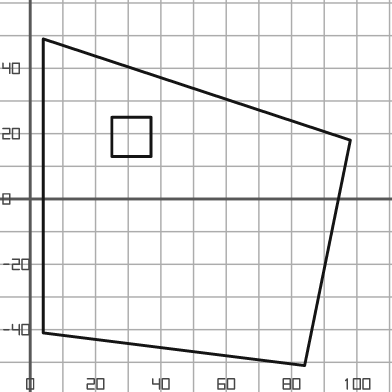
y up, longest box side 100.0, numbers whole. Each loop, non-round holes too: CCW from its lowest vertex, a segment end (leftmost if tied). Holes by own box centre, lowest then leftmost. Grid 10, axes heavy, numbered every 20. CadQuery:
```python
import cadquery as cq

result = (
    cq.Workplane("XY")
    .moveTo(84.0, -51.0)
    .lineTo(98.0, 18.0)
    .lineTo(4.0, 49.0)
    .lineTo(4.0, -41.0)
    .close()
    .moveTo(25.0, 13.0)
    .lineTo(37.0, 13.0)
    .lineTo(37.0, 25.0)
    .lineTo(25.0, 25.0)
    .close()
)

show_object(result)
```